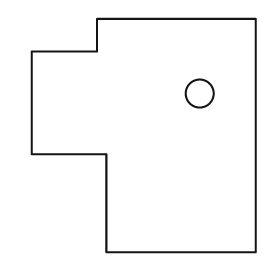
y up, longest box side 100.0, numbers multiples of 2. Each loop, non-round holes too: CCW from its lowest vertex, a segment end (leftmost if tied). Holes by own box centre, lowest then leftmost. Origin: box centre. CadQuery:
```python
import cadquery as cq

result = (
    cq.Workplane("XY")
    .moveTo(-16.0, -50.0)
    .lineTo(48.0, -50.0)
    .lineTo(48.0, 50.0)
    .lineTo(-20.0, 50.0)
    .lineTo(-20.0, 36.0)
    .lineTo(-48.0, 36.0)
    .lineTo(-48.0, -8.0)
    .lineTo(-16.0, -8.0)
    .close()
    .moveTo(24.0, 18.0)
    .circle(6.0)
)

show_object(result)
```